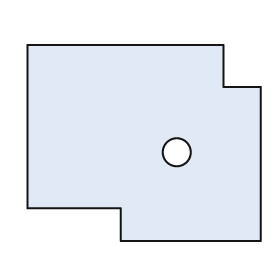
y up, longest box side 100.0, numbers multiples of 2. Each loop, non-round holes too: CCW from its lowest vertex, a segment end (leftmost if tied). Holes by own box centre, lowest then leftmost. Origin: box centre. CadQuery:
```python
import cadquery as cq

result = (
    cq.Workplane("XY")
    .moveTo(-10.0, -42.0)
    .lineTo(50.0, -42.0)
    .lineTo(50.0, 24.0)
    .lineTo(34.0, 24.0)
    .lineTo(34.0, 42.0)
    .lineTo(-50.0, 42.0)
    .lineTo(-50.0, -28.0)
    .lineTo(-10.0, -28.0)
    .close()
    .moveTo(14.0, -4.0)
    .circle(6.0)
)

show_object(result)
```